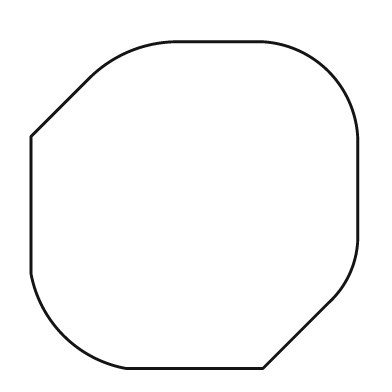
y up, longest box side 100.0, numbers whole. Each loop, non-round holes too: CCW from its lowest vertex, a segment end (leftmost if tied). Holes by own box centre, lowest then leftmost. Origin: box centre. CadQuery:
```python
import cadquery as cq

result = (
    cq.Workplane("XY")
    .moveTo(-21.0, -50.0)
    .lineTo(21.0, -50.0)
    .lineTo(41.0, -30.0)
    .threePointArc((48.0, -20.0), (50.0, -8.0))
    .lineTo(50.0, 21.0)
    .threePointArc((41.0, 41.0), (21.0, 50.0))
    .lineTo(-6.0, 50.0)
    .threePointArc((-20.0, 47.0), (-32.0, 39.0))
    .lineTo(-50.0, 21.0)
    .lineTo(-50.0, -21.0)
    .threePointArc((-40.0, -40.0), (-21.0, -50.0))
    .close()
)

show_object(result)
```